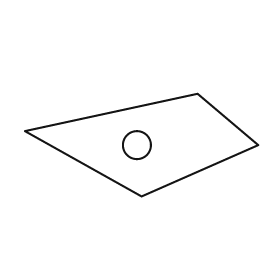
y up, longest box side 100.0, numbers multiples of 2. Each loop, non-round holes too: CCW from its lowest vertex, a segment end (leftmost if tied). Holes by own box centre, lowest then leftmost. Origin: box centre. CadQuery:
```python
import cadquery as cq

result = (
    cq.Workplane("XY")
    .moveTo(0.0, -22.0)
    .lineTo(50.0, 0.0)
    .lineTo(24.0, 22.0)
    .lineTo(-50.0, 6.0)
    .close()
    .moveTo(-2.0, 0.0)
    .circle(6.0)
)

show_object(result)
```